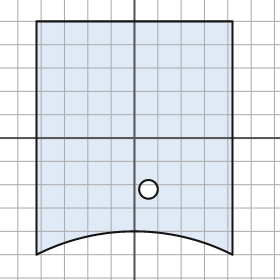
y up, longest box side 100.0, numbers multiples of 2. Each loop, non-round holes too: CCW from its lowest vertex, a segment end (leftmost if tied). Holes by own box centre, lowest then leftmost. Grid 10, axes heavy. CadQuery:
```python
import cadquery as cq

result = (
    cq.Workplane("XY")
    .moveTo(-42.0, -50.0)
    .threePointArc((0.0, -40.0), (42.0, -50.0))
    .lineTo(42.0, 50.0)
    .lineTo(-42.0, 50.0)
    .close()
    .moveTo(6.0, -22.0)
    .circle(4.0)
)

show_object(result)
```